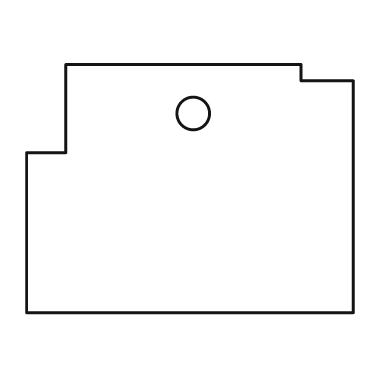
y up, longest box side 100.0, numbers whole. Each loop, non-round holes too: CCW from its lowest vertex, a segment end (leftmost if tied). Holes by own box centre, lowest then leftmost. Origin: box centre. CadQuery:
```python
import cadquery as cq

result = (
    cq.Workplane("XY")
    .moveTo(-50.0, -38.0)
    .lineTo(50.0, -38.0)
    .lineTo(50.0, 33.0)
    .lineTo(34.0, 33.0)
    .lineTo(34.0, 38.0)
    .lineTo(-38.0, 38.0)
    .lineTo(-38.0, 11.0)
    .lineTo(-50.0, 11.0)
    .close()
    .moveTo(1.0, 23.0)
    .circle(5.0)
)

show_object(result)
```